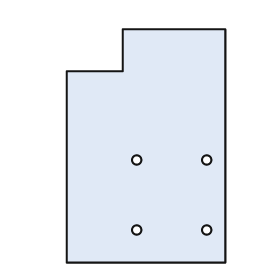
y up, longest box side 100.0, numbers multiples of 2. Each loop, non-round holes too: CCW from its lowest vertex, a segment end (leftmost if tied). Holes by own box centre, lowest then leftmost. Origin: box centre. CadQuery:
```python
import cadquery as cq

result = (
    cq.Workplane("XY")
    .moveTo(-34.0, -50.0)
    .lineTo(34.0, -50.0)
    .lineTo(34.0, 50.0)
    .lineTo(-10.0, 50.0)
    .lineTo(-10.0, 32.0)
    .lineTo(-34.0, 32.0)
    .close()
    .moveTo(-4.0, -36.0)
    .circle(2.0)
    .moveTo(26.0, -36.0)
    .circle(2.0)
    .moveTo(-4.0, -6.0)
    .circle(2.0)
    .moveTo(26.0, -6.0)
    .circle(2.0)
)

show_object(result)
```